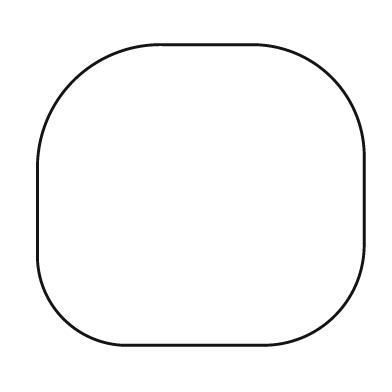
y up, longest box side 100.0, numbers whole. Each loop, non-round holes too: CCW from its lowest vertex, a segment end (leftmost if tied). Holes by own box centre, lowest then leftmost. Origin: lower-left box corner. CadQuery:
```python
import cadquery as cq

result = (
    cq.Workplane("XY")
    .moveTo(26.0, 0.0)
    .lineTo(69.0, 0.0)
    .threePointArc((91.0, 9.0), (100.0, 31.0))
    .lineTo(100.0, 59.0)
    .threePointArc((90.0, 82.0), (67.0, 92.0))
    .lineTo(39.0, 92.0)
    .threePointArc((11.0, 81.0), (0.0, 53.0))
    .lineTo(0.0, 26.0)
    .threePointArc((8.0, 8.0), (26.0, 0.0))
    .close()
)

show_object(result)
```